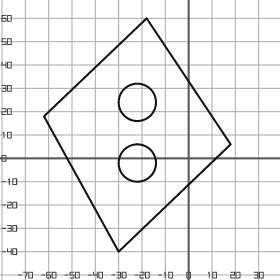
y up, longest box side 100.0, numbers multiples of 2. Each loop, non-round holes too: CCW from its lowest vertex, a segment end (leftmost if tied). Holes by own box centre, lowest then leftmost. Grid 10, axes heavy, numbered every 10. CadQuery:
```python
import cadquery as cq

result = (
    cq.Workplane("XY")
    .moveTo(-30.0, -40.0)
    .lineTo(18.0, 6.0)
    .lineTo(-18.0, 60.0)
    .lineTo(-62.0, 18.0)
    .close()
    .moveTo(-22.0, -2.0)
    .circle(8.0)
    .moveTo(-22.0, 24.0)
    .circle(8.0)
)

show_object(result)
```